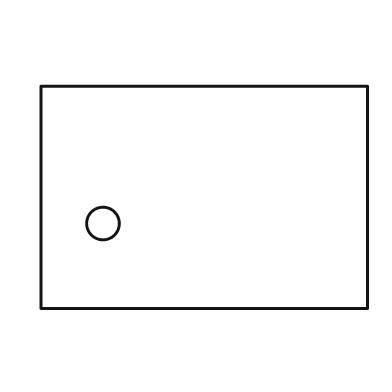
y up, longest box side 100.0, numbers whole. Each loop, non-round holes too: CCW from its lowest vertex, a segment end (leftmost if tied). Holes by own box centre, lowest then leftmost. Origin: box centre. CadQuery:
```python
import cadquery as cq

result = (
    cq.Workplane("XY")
    .moveTo(-50.0, -34.0)
    .lineTo(50.0, -34.0)
    .lineTo(50.0, 34.0)
    .lineTo(-50.0, 34.0)
    .close()
    .moveTo(-31.0, -8.0)
    .circle(5.0)
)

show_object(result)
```